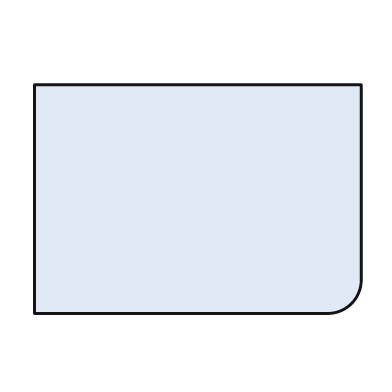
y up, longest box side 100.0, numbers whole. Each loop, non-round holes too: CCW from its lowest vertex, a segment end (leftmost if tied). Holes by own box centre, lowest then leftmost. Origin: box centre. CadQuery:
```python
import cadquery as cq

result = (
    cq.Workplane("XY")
    .moveTo(-50.0, -35.0)
    .lineTo(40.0, -35.0)
    .threePointArc((47.0, -32.0), (50.0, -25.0))
    .lineTo(50.0, 35.0)
    .lineTo(-50.0, 35.0)
    .close()
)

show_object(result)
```